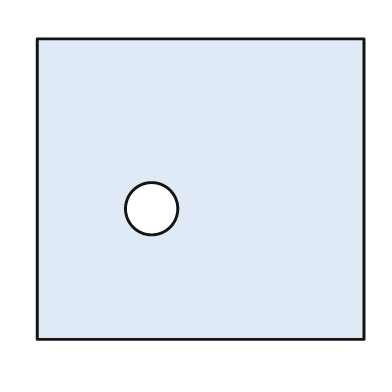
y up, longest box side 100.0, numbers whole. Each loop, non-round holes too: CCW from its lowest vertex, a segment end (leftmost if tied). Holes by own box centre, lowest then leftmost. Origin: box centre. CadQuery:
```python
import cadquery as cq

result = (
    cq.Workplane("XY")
    .moveTo(-50.0, -46.0)
    .lineTo(50.0, -46.0)
    .lineTo(50.0, 46.0)
    .lineTo(-50.0, 46.0)
    .close()
    .moveTo(-15.0, -6.0)
    .circle(8.0)
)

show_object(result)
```